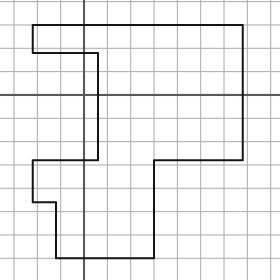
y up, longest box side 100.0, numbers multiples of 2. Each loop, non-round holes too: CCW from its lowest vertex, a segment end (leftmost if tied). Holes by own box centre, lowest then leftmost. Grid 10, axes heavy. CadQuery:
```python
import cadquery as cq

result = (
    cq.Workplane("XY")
    .moveTo(-12.0, -70.0)
    .lineTo(30.0, -70.0)
    .lineTo(30.0, -28.0)
    .lineTo(68.0, -28.0)
    .lineTo(68.0, 30.0)
    .lineTo(-22.0, 30.0)
    .lineTo(-22.0, 18.0)
    .lineTo(6.0, 18.0)
    .lineTo(6.0, -28.0)
    .lineTo(-22.0, -28.0)
    .lineTo(-22.0, -46.0)
    .lineTo(-12.0, -46.0)
    .close()
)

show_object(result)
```